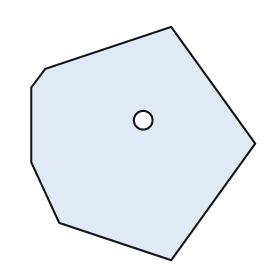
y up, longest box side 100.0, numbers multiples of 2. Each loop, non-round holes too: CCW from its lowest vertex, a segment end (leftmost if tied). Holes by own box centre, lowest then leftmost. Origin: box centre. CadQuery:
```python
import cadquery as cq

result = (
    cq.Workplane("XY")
    .moveTo(12.0, -50.0)
    .lineTo(48.0, 0.0)
    .lineTo(12.0, 50.0)
    .lineTo(-42.0, 32.0)
    .lineTo(-48.0, 24.0)
    .lineTo(-48.0, -8.0)
    .lineTo(-36.0, -34.0)
    .close()
    .moveTo(0.0, 10.0)
    .circle(4.0)
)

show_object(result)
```